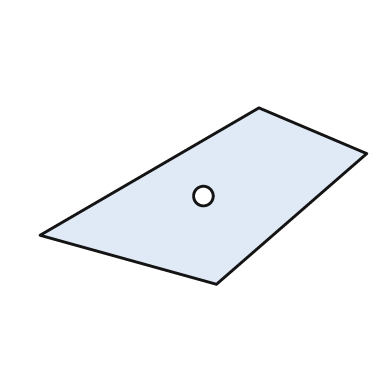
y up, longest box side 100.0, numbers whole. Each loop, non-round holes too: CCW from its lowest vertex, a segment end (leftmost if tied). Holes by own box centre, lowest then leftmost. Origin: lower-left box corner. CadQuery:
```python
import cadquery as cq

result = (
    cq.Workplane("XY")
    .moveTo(54.0, 0.0)
    .lineTo(100.0, 40.0)
    .lineTo(67.0, 54.0)
    .lineTo(0.0, 15.0)
    .close()
    .moveTo(50.0, 27.0)
    .circle(3.0)
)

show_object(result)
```